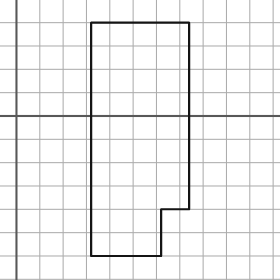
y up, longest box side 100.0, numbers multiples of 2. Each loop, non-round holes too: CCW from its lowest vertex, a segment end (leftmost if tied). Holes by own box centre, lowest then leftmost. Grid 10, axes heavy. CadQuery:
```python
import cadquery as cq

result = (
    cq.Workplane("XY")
    .moveTo(32.0, -60.0)
    .lineTo(62.0, -60.0)
    .lineTo(62.0, -40.0)
    .lineTo(74.0, -40.0)
    .lineTo(74.0, 40.0)
    .lineTo(32.0, 40.0)
    .close()
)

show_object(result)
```